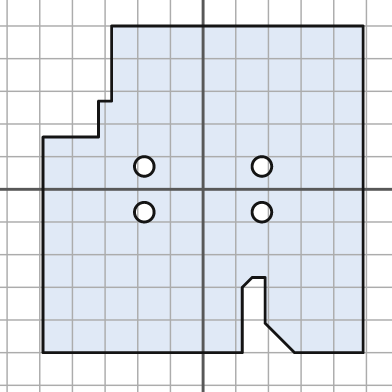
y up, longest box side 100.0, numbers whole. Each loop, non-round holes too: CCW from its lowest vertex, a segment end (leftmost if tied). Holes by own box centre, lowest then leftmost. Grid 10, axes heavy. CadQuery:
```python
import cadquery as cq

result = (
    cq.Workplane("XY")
    .moveTo(-49.0, -50.0)
    .lineTo(12.0, -50.0)
    .lineTo(12.0, -30.0)
    .lineTo(15.0, -27.0)
    .lineTo(19.0, -27.0)
    .lineTo(19.0, -41.0)
    .lineTo(28.0, -50.0)
    .lineTo(49.0, -50.0)
    .lineTo(49.0, 50.0)
    .lineTo(-28.0, 50.0)
    .lineTo(-28.0, 27.0)
    .lineTo(-32.0, 27.0)
    .lineTo(-32.0, 16.0)
    .lineTo(-49.0, 16.0)
    .close()
    .moveTo(-18.0, -7.0)
    .circle(3.0)
    .moveTo(18.0, -7.0)
    .circle(3.0)
    .moveTo(-18.0, 7.0)
    .circle(3.0)
    .moveTo(18.0, 7.0)
    .circle(3.0)
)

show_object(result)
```